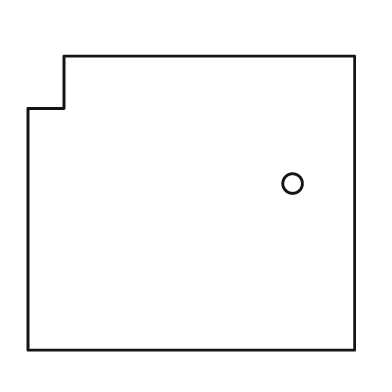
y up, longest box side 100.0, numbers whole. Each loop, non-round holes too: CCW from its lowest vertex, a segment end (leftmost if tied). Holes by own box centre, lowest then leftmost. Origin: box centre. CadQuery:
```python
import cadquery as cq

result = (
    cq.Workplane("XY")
    .moveTo(-50.0, -45.0)
    .lineTo(50.0, -45.0)
    .lineTo(50.0, 45.0)
    .lineTo(-39.0, 45.0)
    .lineTo(-39.0, 29.0)
    .lineTo(-50.0, 29.0)
    .close()
    .moveTo(31.0, 6.0)
    .circle(3.0)
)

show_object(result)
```